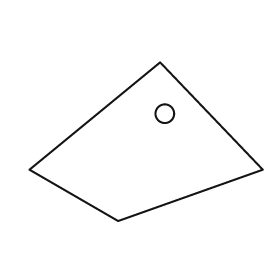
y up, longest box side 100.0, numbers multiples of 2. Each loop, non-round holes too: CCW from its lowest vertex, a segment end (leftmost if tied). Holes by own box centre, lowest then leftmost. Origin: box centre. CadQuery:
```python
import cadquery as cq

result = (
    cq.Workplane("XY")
    .moveTo(-12.0, -34.0)
    .lineTo(50.0, -12.0)
    .lineTo(6.0, 34.0)
    .lineTo(-50.0, -12.0)
    .close()
    .moveTo(8.0, 12.0)
    .circle(4.0)
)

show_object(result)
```